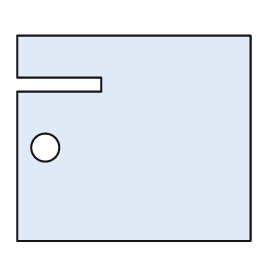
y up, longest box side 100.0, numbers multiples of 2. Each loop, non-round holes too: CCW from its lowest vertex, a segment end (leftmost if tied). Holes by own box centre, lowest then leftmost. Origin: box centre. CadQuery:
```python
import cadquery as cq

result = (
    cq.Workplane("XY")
    .moveTo(-50.0, -44.0)
    .lineTo(50.0, -44.0)
    .lineTo(50.0, 44.0)
    .lineTo(-50.0, 44.0)
    .lineTo(-50.0, 26.0)
    .lineTo(-14.0, 26.0)
    .lineTo(-14.0, 20.0)
    .lineTo(-50.0, 20.0)
    .close()
    .moveTo(-38.0, -4.0)
    .circle(6.0)
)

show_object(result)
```